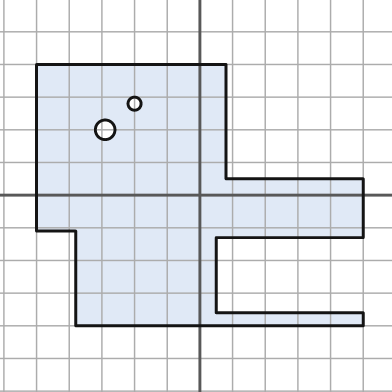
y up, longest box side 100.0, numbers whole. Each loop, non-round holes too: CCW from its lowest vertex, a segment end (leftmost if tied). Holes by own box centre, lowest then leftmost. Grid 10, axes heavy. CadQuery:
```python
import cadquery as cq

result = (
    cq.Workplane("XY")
    .moveTo(-38.0, -40.0)
    .lineTo(50.0, -40.0)
    .lineTo(50.0, -36.0)
    .lineTo(5.0, -36.0)
    .lineTo(5.0, -13.0)
    .lineTo(50.0, -13.0)
    .lineTo(50.0, 5.0)
    .lineTo(8.0, 5.0)
    .lineTo(8.0, 40.0)
    .lineTo(-50.0, 40.0)
    .lineTo(-50.0, -11.0)
    .lineTo(-38.0, -11.0)
    .close()
    .moveTo(-29.0, 20.0)
    .circle(3.0)
    .moveTo(-20.0, 28.0)
    .circle(2.0)
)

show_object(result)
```